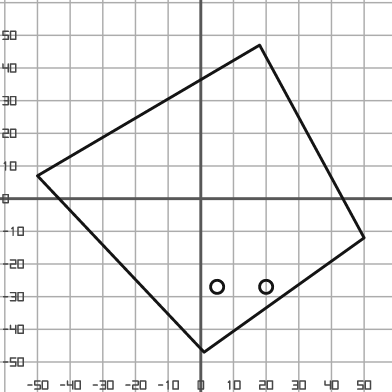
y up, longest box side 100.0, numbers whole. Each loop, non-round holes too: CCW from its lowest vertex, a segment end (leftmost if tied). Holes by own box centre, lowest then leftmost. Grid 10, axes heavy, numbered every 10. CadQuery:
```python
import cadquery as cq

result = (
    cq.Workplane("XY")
    .moveTo(1.0, -47.0)
    .lineTo(50.0, -12.0)
    .lineTo(18.0, 47.0)
    .lineTo(-50.0, 7.0)
    .close()
    .moveTo(5.0, -27.0)
    .circle(2.0)
    .moveTo(20.0, -27.0)
    .circle(2.0)
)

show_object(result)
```